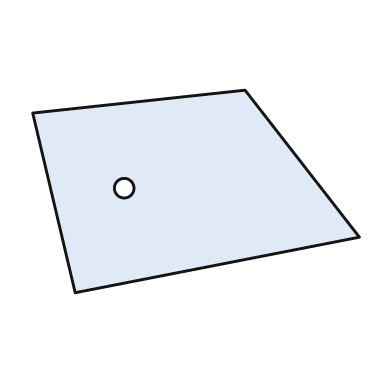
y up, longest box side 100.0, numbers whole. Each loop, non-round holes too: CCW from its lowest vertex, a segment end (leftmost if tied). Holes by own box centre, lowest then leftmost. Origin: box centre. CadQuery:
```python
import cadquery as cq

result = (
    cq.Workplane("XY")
    .moveTo(-37.0, -31.0)
    .lineTo(50.0, -14.0)
    .lineTo(15.0, 31.0)
    .lineTo(-50.0, 24.0)
    .close()
    .moveTo(-22.0, 1.0)
    .circle(3.0)
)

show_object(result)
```